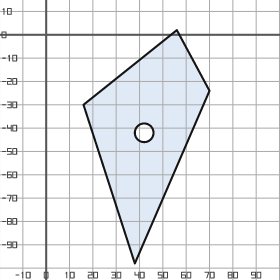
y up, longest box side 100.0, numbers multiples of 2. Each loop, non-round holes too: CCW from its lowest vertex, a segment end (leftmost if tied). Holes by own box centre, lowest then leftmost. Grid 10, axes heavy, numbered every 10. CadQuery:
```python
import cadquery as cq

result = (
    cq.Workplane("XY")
    .moveTo(38.0, -98.0)
    .lineTo(70.0, -24.0)
    .lineTo(56.0, 2.0)
    .lineTo(16.0, -30.0)
    .close()
    .moveTo(42.0, -42.0)
    .circle(4.0)
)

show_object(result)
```